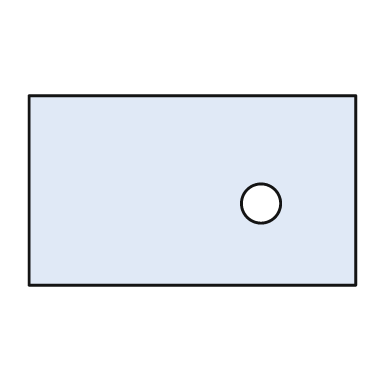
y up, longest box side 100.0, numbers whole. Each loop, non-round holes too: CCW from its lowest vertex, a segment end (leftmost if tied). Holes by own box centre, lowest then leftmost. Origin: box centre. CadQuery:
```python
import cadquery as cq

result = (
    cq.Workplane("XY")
    .moveTo(-50.0, -29.0)
    .lineTo(50.0, -29.0)
    .lineTo(50.0, 29.0)
    .lineTo(-50.0, 29.0)
    .close()
    .moveTo(21.0, -4.0)
    .circle(6.0)
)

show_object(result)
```